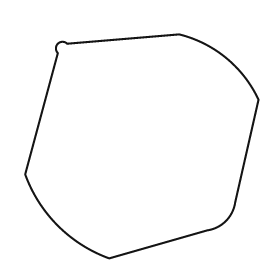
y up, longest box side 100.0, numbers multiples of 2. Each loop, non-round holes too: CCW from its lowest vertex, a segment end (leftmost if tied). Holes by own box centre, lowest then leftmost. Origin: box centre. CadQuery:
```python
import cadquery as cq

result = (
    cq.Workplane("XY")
    .moveTo(-14.0, -48.0)
    .lineTo(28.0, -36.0)
    .threePointArc((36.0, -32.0), (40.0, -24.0))
    .lineTo(50.0, 20.0)
    .threePointArc((36.0, 38.0), (16.0, 48.0))
    .lineTo(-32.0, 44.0)
    .threePointArc((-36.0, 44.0), (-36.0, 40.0))
    .lineTo(-50.0, -12.0)
    .threePointArc((-36.0, -34.0), (-14.0, -48.0))
    .close()
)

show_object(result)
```